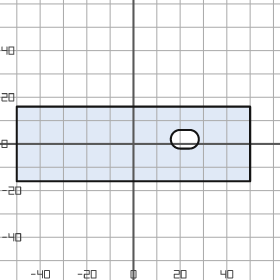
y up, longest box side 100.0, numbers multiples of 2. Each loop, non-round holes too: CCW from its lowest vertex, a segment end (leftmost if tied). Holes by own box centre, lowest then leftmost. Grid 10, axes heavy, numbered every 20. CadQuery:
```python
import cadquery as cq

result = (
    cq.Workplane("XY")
    .moveTo(-50.0, -16.0)
    .lineTo(50.0, -16.0)
    .lineTo(50.0, 16.0)
    .lineTo(-50.0, 16.0)
    .close()
    .moveTo(20.0, -2.0)
    .lineTo(24.0, -2.0)
    .threePointArc((28.0, 2.0), (24.0, 6.0))
    .lineTo(20.0, 6.0)
    .threePointArc((16.0, 2.0), (20.0, -2.0))
    .close()
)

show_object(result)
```